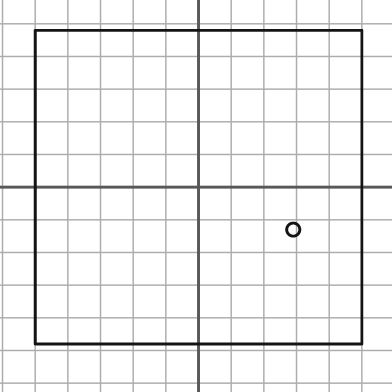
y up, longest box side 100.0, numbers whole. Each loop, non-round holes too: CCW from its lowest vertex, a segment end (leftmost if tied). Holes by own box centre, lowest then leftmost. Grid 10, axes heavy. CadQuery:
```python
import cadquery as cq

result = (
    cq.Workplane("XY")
    .moveTo(-50.0, -48.0)
    .lineTo(50.0, -48.0)
    .lineTo(50.0, 48.0)
    .lineTo(-50.0, 48.0)
    .close()
    .moveTo(29.0, -13.0)
    .circle(2.0)
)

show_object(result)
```